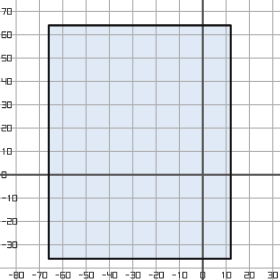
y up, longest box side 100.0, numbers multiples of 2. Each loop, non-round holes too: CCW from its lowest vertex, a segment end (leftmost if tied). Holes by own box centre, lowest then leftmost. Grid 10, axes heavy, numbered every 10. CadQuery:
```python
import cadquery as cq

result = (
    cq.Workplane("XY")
    .moveTo(-66.0, -36.0)
    .lineTo(12.0, -36.0)
    .lineTo(12.0, 64.0)
    .lineTo(-66.0, 64.0)
    .close()
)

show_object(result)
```